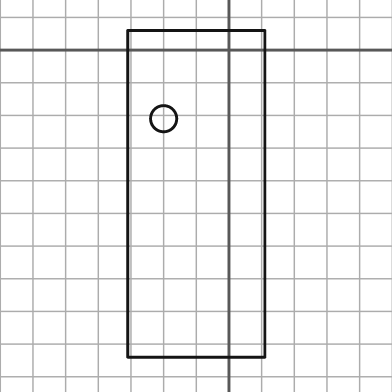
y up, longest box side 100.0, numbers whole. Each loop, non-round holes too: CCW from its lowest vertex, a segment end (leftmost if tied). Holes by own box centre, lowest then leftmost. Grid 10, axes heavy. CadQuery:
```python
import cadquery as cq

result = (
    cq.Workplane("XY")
    .moveTo(-31.0, -94.0)
    .lineTo(11.0, -94.0)
    .lineTo(11.0, 6.0)
    .lineTo(-31.0, 6.0)
    .close()
    .moveTo(-20.0, -21.0)
    .circle(4.0)
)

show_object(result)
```